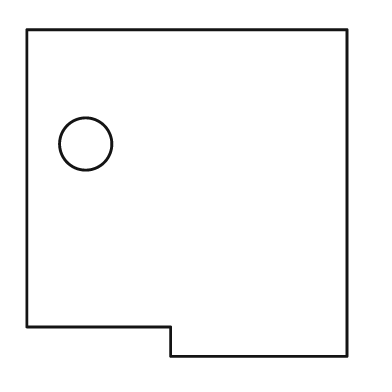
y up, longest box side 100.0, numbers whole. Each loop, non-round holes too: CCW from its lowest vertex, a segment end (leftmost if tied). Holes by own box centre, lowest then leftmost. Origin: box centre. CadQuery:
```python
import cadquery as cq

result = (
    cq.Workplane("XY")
    .moveTo(-5.0, -50.0)
    .lineTo(49.0, -50.0)
    .lineTo(49.0, 50.0)
    .lineTo(-49.0, 50.0)
    .lineTo(-49.0, -41.0)
    .lineTo(-5.0, -41.0)
    .close()
    .moveTo(-31.0, 15.0)
    .circle(8.0)
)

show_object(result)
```